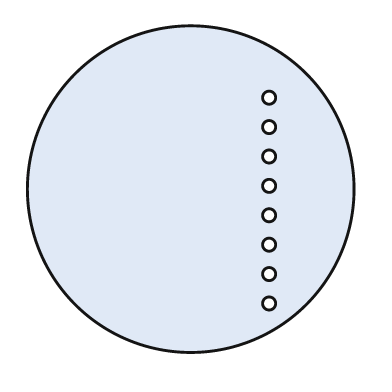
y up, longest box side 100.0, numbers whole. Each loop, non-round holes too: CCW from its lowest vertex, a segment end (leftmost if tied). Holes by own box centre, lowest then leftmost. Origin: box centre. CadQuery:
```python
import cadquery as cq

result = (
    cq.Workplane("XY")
    .moveTo(0.0, 0.0)
    .circle(50.0)
    .moveTo(24.0, -35.0)
    .circle(2.0)
    .moveTo(24.0, -26.0)
    .circle(2.0)
    .moveTo(24.0, -17.0)
    .circle(2.0)
    .moveTo(24.0, -8.0)
    .circle(2.0)
    .moveTo(24.0, 1.0)
    .circle(2.0)
    .moveTo(24.0, 10.0)
    .circle(2.0)
    .moveTo(24.0, 19.0)
    .circle(2.0)
    .moveTo(24.0, 28.0)
    .circle(2.0)
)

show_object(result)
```